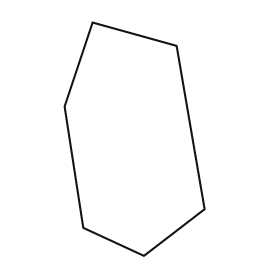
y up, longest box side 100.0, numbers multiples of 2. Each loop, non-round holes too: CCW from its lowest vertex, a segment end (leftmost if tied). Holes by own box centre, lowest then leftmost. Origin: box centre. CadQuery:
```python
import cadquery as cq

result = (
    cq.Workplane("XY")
    .moveTo(4.0, -50.0)
    .lineTo(30.0, -30.0)
    .lineTo(18.0, 40.0)
    .lineTo(-18.0, 50.0)
    .lineTo(-30.0, 14.0)
    .lineTo(-22.0, -38.0)
    .close()
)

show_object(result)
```